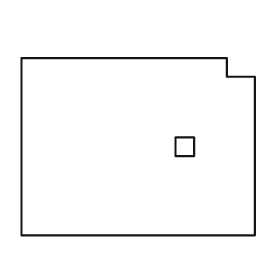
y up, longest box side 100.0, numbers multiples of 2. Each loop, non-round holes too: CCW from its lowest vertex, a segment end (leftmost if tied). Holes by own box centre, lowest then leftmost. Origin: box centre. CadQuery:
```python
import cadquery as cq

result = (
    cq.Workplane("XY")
    .moveTo(-50.0, -38.0)
    .lineTo(50.0, -38.0)
    .lineTo(50.0, 30.0)
    .lineTo(38.0, 30.0)
    .lineTo(38.0, 38.0)
    .lineTo(-50.0, 38.0)
    .close()
    .moveTo(16.0, -4.0)
    .lineTo(24.0, -4.0)
    .lineTo(24.0, 4.0)
    .lineTo(16.0, 4.0)
    .close()
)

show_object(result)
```